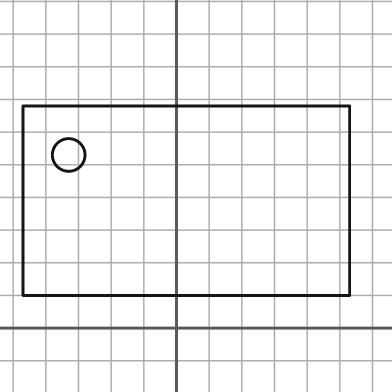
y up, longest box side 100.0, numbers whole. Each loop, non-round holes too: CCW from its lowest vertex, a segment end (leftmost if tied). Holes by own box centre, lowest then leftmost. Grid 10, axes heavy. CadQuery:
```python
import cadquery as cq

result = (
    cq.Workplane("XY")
    .moveTo(-47.0, 10.0)
    .lineTo(53.0, 10.0)
    .lineTo(53.0, 68.0)
    .lineTo(-47.0, 68.0)
    .close()
    .moveTo(-33.0, 53.0)
    .circle(5.0)
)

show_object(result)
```